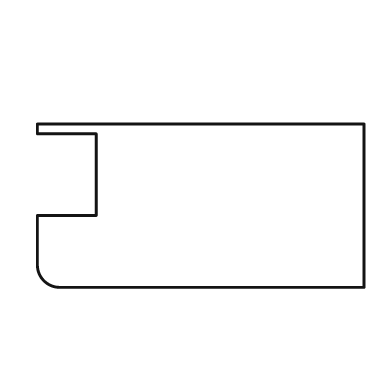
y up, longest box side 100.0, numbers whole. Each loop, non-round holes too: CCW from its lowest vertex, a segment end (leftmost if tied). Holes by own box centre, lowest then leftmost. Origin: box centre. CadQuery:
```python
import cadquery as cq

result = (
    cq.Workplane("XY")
    .moveTo(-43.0, -25.0)
    .lineTo(50.0, -25.0)
    .lineTo(50.0, 25.0)
    .lineTo(-50.0, 25.0)
    .lineTo(-50.0, 22.0)
    .lineTo(-32.0, 22.0)
    .lineTo(-32.0, -3.0)
    .lineTo(-50.0, -3.0)
    .lineTo(-50.0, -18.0)
    .threePointArc((-48.0, -23.0), (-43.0, -25.0))
    .close()
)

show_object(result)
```